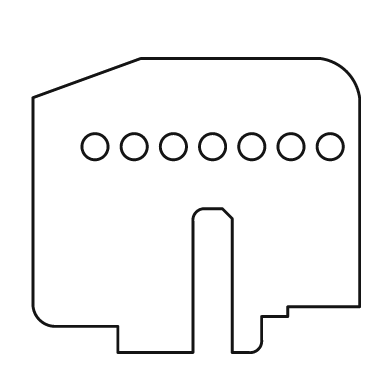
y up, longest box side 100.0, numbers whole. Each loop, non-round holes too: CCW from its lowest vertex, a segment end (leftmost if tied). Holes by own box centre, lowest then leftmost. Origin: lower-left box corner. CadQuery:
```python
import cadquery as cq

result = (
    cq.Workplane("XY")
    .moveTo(26.0, 0.0)
    .lineTo(49.0, 0.0)
    .lineTo(49.0, 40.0)
    .threePointArc((50.0, 43.0), (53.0, 44.0))
    .lineTo(58.0, 44.0)
    .lineTo(61.0, 41.0)
    .lineTo(61.0, 0.0)
    .lineTo(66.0, 0.0)
    .threePointArc((69.0, 1.0), (70.0, 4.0))
    .lineTo(70.0, 11.0)
    .lineTo(78.0, 11.0)
    .lineTo(78.0, 14.0)
    .lineTo(100.0, 14.0)
    .lineTo(100.0, 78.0)
    .threePointArc((96.0, 86.0), (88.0, 90.0))
    .lineTo(33.0, 90.0)
    .lineTo(0.0, 78.0)
    .lineTo(0.0, 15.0)
    .threePointArc((2.0, 10.0), (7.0, 8.0))
    .lineTo(26.0, 8.0)
    .close()
    .moveTo(19.0, 63.0)
    .circle(4.0)
    .moveTo(31.0, 63.0)
    .circle(4.0)
    .moveTo(43.0, 63.0)
    .circle(4.0)
    .moveTo(55.0, 63.0)
    .circle(4.0)
    .moveTo(67.0, 63.0)
    .circle(4.0)
    .moveTo(79.0, 63.0)
    .circle(4.0)
    .moveTo(91.0, 63.0)
    .circle(4.0)
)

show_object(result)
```